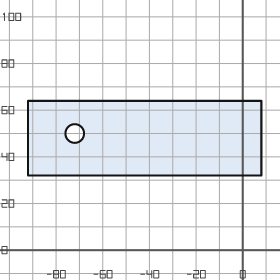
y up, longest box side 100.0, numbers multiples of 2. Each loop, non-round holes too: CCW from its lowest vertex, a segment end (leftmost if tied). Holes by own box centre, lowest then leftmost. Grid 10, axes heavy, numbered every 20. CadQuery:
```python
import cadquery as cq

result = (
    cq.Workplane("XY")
    .moveTo(-92.0, 32.0)
    .lineTo(8.0, 32.0)
    .lineTo(8.0, 64.0)
    .lineTo(-92.0, 64.0)
    .close()
    .moveTo(-72.0, 50.0)
    .circle(4.0)
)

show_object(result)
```